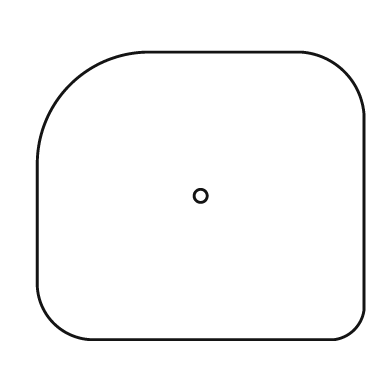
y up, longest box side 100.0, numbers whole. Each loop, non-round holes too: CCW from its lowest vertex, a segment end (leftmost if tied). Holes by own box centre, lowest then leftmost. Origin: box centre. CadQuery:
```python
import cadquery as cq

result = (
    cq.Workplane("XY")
    .moveTo(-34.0, -44.0)
    .lineTo(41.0, -44.0)
    .threePointArc((47.0, -41.0), (50.0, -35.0))
    .lineTo(50.0, 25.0)
    .threePointArc((44.0, 38.0), (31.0, 44.0))
    .lineTo(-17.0, 44.0)
    .threePointArc((-40.0, 34.0), (-50.0, 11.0))
    .lineTo(-50.0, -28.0)
    .threePointArc((-45.0, -39.0), (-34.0, -44.0))
    .close()
    .moveTo(0.0, 0.0)
    .circle(2.0)
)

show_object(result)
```